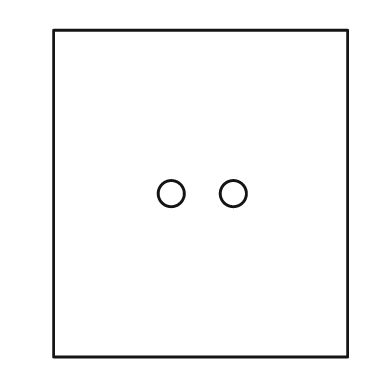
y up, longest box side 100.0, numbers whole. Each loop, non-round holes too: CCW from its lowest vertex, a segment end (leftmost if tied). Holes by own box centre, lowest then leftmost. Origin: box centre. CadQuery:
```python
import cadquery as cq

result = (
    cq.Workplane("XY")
    .moveTo(-45.0, -50.0)
    .lineTo(45.0, -50.0)
    .lineTo(45.0, 50.0)
    .lineTo(-45.0, 50.0)
    .close()
    .moveTo(-9.0, 0.0)
    .circle(4.0)
    .moveTo(10.0, 0.0)
    .circle(4.0)
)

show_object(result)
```